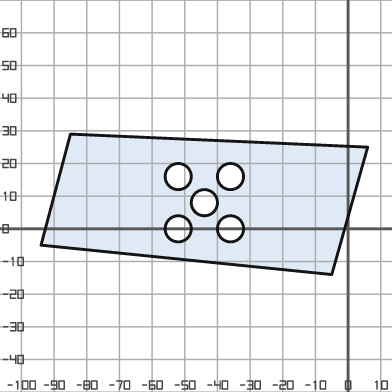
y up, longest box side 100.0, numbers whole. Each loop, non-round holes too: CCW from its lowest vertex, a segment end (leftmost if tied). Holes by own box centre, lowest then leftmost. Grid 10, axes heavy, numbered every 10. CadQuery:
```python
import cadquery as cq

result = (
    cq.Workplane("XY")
    .moveTo(-5.0, -14.0)
    .lineTo(6.0, 25.0)
    .lineTo(-85.0, 29.0)
    .lineTo(-94.0, -5.0)
    .close()
    .moveTo(-52.0, 0.0)
    .circle(4.0)
    .moveTo(-36.0, 0.0)
    .circle(4.0)
    .moveTo(-44.0, 8.0)
    .circle(4.0)
    .moveTo(-52.0, 16.0)
    .circle(4.0)
    .moveTo(-36.0, 16.0)
    .circle(4.0)
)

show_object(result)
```